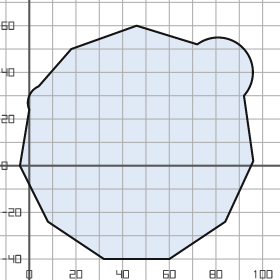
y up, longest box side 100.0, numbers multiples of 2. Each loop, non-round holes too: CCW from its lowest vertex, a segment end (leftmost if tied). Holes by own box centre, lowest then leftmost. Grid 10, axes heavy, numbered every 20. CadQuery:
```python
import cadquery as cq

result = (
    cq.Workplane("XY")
    .moveTo(32.0, -40.0)
    .lineTo(60.0, -40.0)
    .lineTo(84.0, -24.0)
    .lineTo(96.0, 2.0)
    .lineTo(92.0, 30.0)
    .threePointArc((92.0, 50.0), (72.0, 52.0))
    .lineTo(46.0, 60.0)
    .lineTo(18.0, 50.0)
    .lineTo(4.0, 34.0)
    .threePointArc((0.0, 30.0), (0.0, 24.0))
    .lineTo(-4.0, 0.0)
    .lineTo(8.0, -24.0)
    .close()
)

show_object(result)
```